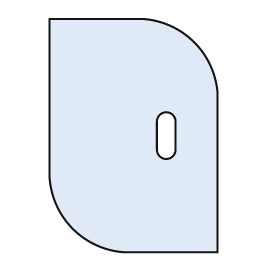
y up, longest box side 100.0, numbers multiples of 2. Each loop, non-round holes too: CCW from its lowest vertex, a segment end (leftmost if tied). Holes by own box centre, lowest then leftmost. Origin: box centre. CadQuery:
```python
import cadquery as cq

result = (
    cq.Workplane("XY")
    .moveTo(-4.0, -50.0)
    .lineTo(36.0, -50.0)
    .lineTo(36.0, 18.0)
    .threePointArc((26.0, 40.0), (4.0, 50.0))
    .lineTo(-36.0, 50.0)
    .lineTo(-36.0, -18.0)
    .threePointArc((-26.0, -40.0), (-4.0, -50.0))
    .close()
    .moveTo(10.0, -6.0)
    .threePointArc((14.0, -10.0), (18.0, -6.0))
    .lineTo(18.0, 6.0)
    .threePointArc((14.0, 10.0), (10.0, 6.0))
    .close()
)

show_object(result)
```